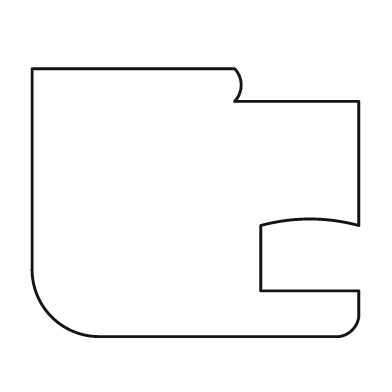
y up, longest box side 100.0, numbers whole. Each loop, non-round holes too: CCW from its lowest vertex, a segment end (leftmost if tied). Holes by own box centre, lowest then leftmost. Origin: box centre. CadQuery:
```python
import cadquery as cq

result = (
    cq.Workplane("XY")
    .moveTo(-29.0, -41.0)
    .lineTo(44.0, -41.0)
    .threePointArc((48.0, -39.0), (50.0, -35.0))
    .lineTo(50.0, -27.0)
    .lineTo(20.0, -27.0)
    .lineTo(20.0, -7.0)
    .threePointArc((35.0, -5.0), (50.0, -7.0))
    .lineTo(50.0, 31.0)
    .lineTo(12.0, 31.0)
    .threePointArc((14.0, 36.0), (12.0, 41.0))
    .lineTo(-50.0, 41.0)
    .lineTo(-50.0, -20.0)
    .threePointArc((-44.0, -35.0), (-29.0, -41.0))
    .close()
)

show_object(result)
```